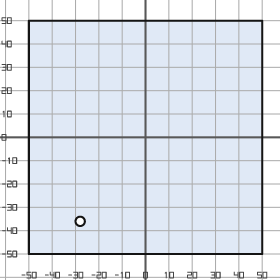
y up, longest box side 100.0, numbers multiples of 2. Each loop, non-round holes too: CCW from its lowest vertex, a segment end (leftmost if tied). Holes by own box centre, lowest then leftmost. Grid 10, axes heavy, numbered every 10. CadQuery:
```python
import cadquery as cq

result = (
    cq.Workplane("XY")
    .moveTo(-50.0, -50.0)
    .lineTo(50.0, -50.0)
    .lineTo(50.0, 50.0)
    .lineTo(-50.0, 50.0)
    .close()
    .moveTo(-28.0, -36.0)
    .circle(2.0)
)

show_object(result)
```